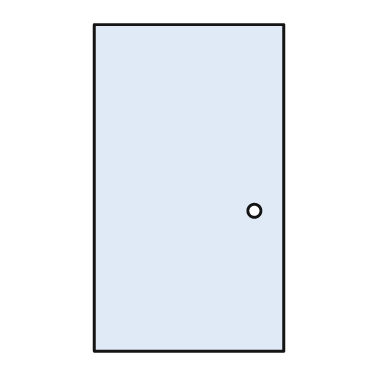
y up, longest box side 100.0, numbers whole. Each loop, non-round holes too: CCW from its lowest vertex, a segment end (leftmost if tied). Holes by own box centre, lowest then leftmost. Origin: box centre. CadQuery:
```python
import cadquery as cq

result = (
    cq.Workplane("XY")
    .moveTo(-29.0, -50.0)
    .lineTo(29.0, -50.0)
    .lineTo(29.0, 50.0)
    .lineTo(-29.0, 50.0)
    .close()
    .moveTo(20.0, -7.0)
    .circle(2.0)
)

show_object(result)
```